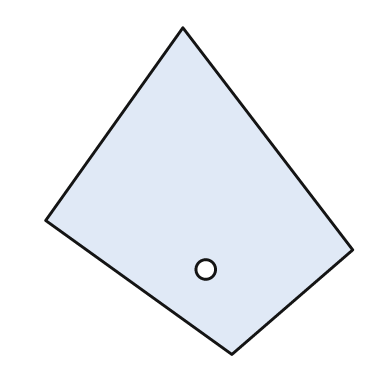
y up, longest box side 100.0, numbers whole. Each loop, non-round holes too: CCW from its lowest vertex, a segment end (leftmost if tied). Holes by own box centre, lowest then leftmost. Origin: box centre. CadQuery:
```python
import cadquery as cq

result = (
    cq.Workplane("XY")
    .moveTo(10.0, -50.0)
    .lineTo(47.0, -18.0)
    .lineTo(-5.0, 50.0)
    .lineTo(-47.0, -9.0)
    .close()
    .moveTo(2.0, -24.0)
    .circle(3.0)
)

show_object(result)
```